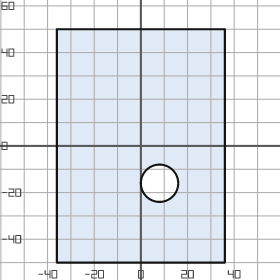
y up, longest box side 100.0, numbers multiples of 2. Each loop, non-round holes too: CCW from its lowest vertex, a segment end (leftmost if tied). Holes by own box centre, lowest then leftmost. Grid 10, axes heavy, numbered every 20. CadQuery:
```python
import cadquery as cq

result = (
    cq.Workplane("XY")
    .moveTo(-36.0, -50.0)
    .lineTo(36.0, -50.0)
    .lineTo(36.0, 50.0)
    .lineTo(-36.0, 50.0)
    .close()
    .moveTo(8.0, -16.0)
    .circle(8.0)
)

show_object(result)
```